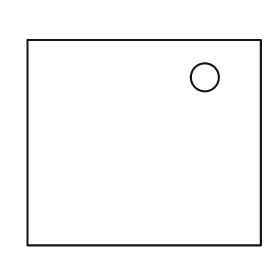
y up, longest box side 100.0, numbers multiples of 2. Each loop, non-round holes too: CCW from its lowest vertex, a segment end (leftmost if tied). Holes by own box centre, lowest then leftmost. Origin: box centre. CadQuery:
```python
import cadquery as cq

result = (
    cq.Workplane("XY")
    .moveTo(-50.0, -44.0)
    .lineTo(50.0, -44.0)
    .lineTo(50.0, 44.0)
    .lineTo(-50.0, 44.0)
    .close()
    .moveTo(26.0, 28.0)
    .circle(6.0)
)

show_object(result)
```